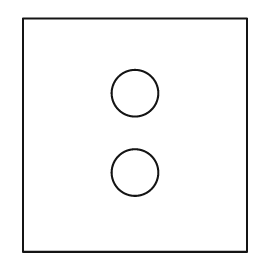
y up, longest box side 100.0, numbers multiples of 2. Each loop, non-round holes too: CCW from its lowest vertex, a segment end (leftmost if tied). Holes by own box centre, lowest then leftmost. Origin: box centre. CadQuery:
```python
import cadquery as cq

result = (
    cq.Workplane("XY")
    .moveTo(-48.0, -50.0)
    .lineTo(48.0, -50.0)
    .lineTo(48.0, 50.0)
    .lineTo(-48.0, 50.0)
    .close()
    .moveTo(0.0, -16.0)
    .circle(10.0)
    .moveTo(0.0, 18.0)
    .circle(10.0)
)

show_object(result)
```